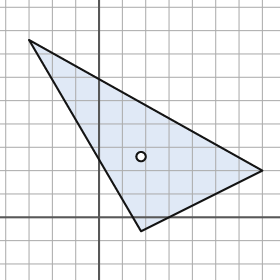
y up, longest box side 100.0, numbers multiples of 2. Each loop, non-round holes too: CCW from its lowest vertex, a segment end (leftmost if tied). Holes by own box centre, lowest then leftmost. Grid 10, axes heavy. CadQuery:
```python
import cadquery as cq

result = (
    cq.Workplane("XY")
    .moveTo(18.0, -6.0)
    .lineTo(70.0, 20.0)
    .lineTo(-30.0, 76.0)
    .close()
    .moveTo(18.0, 26.0)
    .circle(2.0)
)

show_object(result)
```